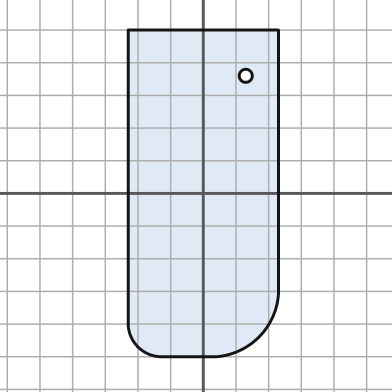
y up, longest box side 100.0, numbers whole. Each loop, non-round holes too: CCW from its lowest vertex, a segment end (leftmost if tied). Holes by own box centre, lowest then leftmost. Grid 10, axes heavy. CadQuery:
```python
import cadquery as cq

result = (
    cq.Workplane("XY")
    .moveTo(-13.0, -50.0)
    .lineTo(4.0, -50.0)
    .threePointArc((17.0, -44.0), (23.0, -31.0))
    .lineTo(23.0, 50.0)
    .lineTo(-23.0, 50.0)
    .lineTo(-23.0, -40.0)
    .threePointArc((-20.0, -47.0), (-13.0, -50.0))
    .close()
    .moveTo(13.0, 36.0)
    .circle(2.0)
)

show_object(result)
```